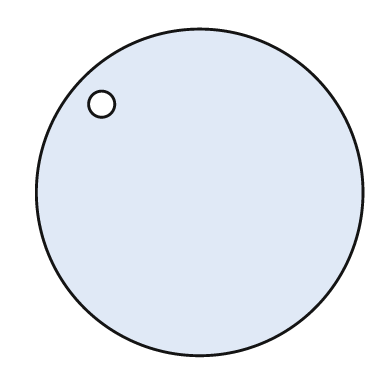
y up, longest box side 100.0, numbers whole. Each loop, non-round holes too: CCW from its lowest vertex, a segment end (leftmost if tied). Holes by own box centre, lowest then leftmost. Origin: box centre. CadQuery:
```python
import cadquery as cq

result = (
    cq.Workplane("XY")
    .moveTo(0.0, 0.0)
    .circle(50.0)
    .moveTo(-30.0, 27.0)
    .circle(4.0)
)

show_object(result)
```